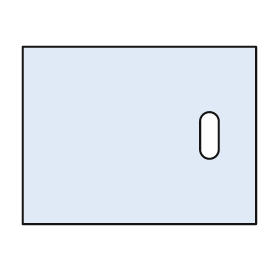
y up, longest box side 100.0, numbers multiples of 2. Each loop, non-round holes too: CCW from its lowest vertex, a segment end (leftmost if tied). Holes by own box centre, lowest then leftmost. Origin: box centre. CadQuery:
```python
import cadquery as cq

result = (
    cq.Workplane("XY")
    .moveTo(-50.0, -38.0)
    .lineTo(50.0, -38.0)
    .lineTo(50.0, 38.0)
    .lineTo(-50.0, 38.0)
    .close()
    .moveTo(26.0, -6.0)
    .threePointArc((30.0, -10.0), (34.0, -6.0))
    .lineTo(34.0, 6.0)
    .threePointArc((30.0, 10.0), (26.0, 6.0))
    .close()
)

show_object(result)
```